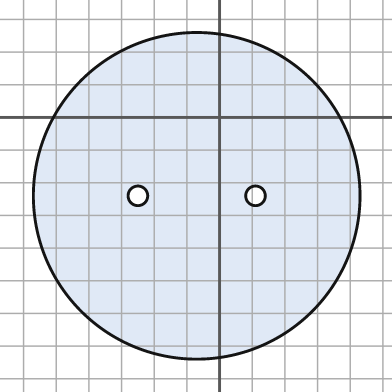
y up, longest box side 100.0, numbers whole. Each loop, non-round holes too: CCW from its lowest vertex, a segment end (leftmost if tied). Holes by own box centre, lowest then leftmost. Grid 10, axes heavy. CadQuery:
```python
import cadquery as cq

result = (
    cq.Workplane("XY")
    .moveTo(-7.0, -24.0)
    .circle(50.0)
    .moveTo(-25.0, -24.0)
    .circle(3.0)
    .moveTo(11.0, -24.0)
    .circle(3.0)
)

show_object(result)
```